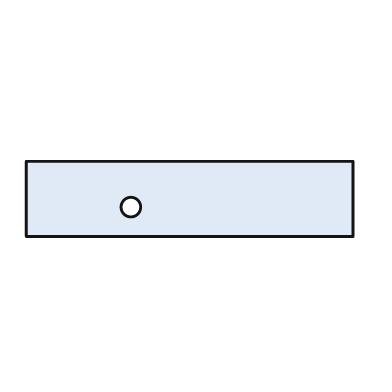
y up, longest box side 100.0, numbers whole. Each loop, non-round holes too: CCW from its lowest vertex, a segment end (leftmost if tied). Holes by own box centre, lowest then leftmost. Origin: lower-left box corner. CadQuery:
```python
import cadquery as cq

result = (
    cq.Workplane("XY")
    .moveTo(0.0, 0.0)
    .lineTo(100.0, 0.0)
    .lineTo(100.0, 23.0)
    .lineTo(0.0, 23.0)
    .close()
    .moveTo(32.0, 9.0)
    .circle(3.0)
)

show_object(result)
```